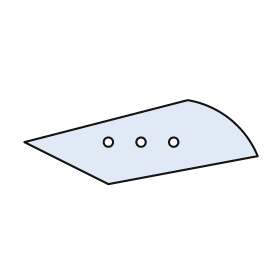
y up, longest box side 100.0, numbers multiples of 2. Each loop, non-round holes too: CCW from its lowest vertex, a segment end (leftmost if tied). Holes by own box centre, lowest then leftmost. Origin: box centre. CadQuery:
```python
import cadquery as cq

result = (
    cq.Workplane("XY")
    .moveTo(-14.0, -18.0)
    .lineTo(50.0, -6.0)
    .threePointArc((38.0, 10.0), (20.0, 18.0))
    .lineTo(-50.0, 0.0)
    .close()
    .moveTo(-14.0, 0.0)
    .circle(2.0)
    .moveTo(0.0, 0.0)
    .circle(2.0)
    .moveTo(14.0, 0.0)
    .circle(2.0)
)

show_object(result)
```